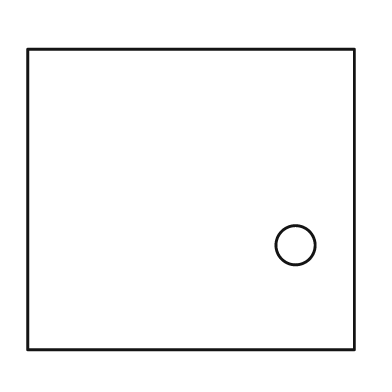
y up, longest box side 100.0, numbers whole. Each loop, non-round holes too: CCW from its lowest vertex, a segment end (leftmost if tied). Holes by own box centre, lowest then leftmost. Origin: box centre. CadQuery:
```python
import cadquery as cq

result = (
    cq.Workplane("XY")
    .moveTo(-50.0, -46.0)
    .lineTo(50.0, -46.0)
    .lineTo(50.0, 46.0)
    .lineTo(-50.0, 46.0)
    .close()
    .moveTo(32.0, -14.0)
    .circle(6.0)
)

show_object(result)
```